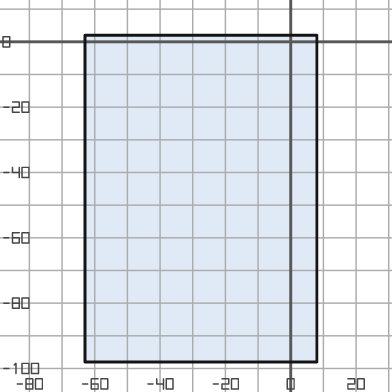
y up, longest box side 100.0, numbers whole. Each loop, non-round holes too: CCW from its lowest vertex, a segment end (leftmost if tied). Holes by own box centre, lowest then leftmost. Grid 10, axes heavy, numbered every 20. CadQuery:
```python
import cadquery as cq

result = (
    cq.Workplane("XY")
    .moveTo(-63.0, -98.0)
    .lineTo(8.0, -98.0)
    .lineTo(8.0, 2.0)
    .lineTo(-63.0, 2.0)
    .close()
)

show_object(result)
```